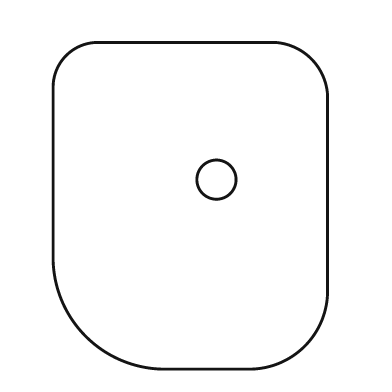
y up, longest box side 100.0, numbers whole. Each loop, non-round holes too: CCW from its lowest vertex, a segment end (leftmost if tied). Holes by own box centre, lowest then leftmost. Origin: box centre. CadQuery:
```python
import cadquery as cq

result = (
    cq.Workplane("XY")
    .moveTo(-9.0, -50.0)
    .lineTo(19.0, -50.0)
    .threePointArc((35.0, -43.0), (42.0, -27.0))
    .lineTo(42.0, 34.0)
    .threePointArc((37.0, 45.0), (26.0, 50.0))
    .lineTo(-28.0, 50.0)
    .threePointArc((-38.0, 46.0), (-42.0, 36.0))
    .lineTo(-42.0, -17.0)
    .threePointArc((-32.0, -40.0), (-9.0, -50.0))
    .close()
    .moveTo(8.0, 8.0)
    .circle(6.0)
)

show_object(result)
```